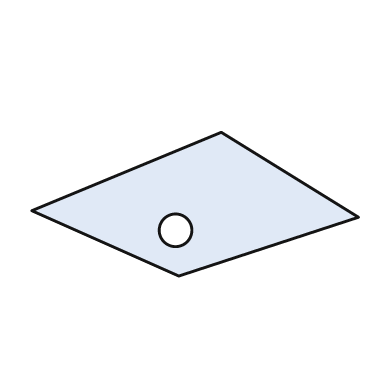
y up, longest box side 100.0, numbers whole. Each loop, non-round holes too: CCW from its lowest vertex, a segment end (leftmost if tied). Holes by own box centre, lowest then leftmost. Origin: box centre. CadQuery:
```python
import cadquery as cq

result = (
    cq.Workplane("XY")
    .moveTo(-5.0, -22.0)
    .lineTo(50.0, -4.0)
    .lineTo(8.0, 22.0)
    .lineTo(-50.0, -2.0)
    .close()
    .moveTo(-6.0, -8.0)
    .circle(5.0)
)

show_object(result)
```